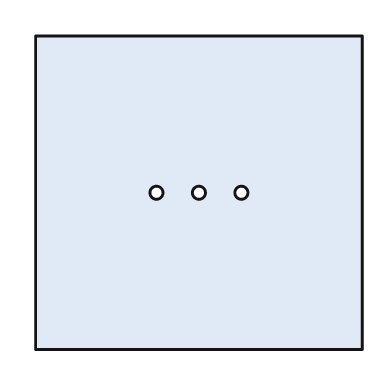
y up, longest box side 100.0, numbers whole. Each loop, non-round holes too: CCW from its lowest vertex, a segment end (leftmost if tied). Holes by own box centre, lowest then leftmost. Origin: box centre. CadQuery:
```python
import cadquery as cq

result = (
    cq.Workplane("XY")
    .moveTo(-50.0, -48.0)
    .lineTo(50.0, -48.0)
    .lineTo(50.0, 48.0)
    .lineTo(-50.0, 48.0)
    .close()
    .moveTo(-13.0, 0.0)
    .circle(2.0)
    .moveTo(0.0, 0.0)
    .circle(2.0)
    .moveTo(13.0, 0.0)
    .circle(2.0)
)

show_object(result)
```